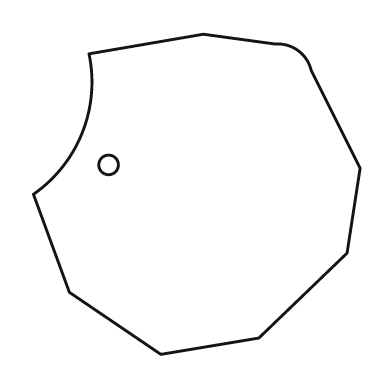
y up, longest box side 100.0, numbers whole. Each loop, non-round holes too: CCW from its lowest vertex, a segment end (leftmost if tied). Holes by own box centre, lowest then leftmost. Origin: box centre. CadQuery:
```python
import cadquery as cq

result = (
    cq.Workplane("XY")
    .moveTo(-11.0, -49.0)
    .lineTo(19.0, -44.0)
    .lineTo(46.0, -18.0)
    .lineTo(50.0, 8.0)
    .lineTo(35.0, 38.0)
    .threePointArc((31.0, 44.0), (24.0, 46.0))
    .lineTo(2.0, 49.0)
    .lineTo(-33.0, 43.0)
    .threePointArc((-35.0, 19.0), (-50.0, 0.0))
    .lineTo(-39.0, -30.0)
    .close()
    .moveTo(-27.0, 9.0)
    .circle(3.0)
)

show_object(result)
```